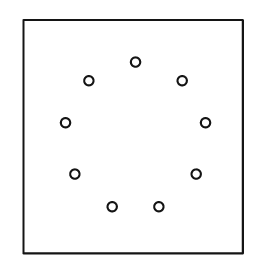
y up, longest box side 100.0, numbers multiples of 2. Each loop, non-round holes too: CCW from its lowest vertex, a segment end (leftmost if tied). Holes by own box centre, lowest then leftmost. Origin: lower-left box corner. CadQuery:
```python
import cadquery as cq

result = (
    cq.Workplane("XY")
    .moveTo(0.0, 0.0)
    .lineTo(94.0, 0.0)
    .lineTo(94.0, 100.0)
    .lineTo(0.0, 100.0)
    .close()
    .moveTo(38.0, 20.0)
    .circle(2.0)
    .moveTo(58.0, 20.0)
    .circle(2.0)
    .moveTo(22.0, 34.0)
    .circle(2.0)
    .moveTo(74.0, 34.0)
    .circle(2.0)
    .moveTo(18.0, 56.0)
    .circle(2.0)
    .moveTo(78.0, 56.0)
    .circle(2.0)
    .moveTo(28.0, 74.0)
    .circle(2.0)
    .moveTo(68.0, 74.0)
    .circle(2.0)
    .moveTo(48.0, 82.0)
    .circle(2.0)
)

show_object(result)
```